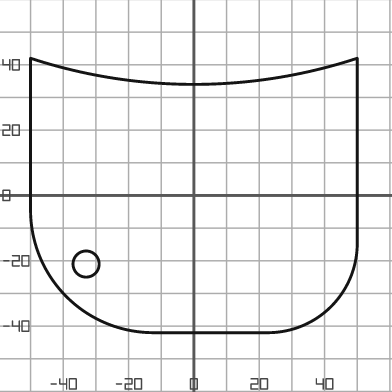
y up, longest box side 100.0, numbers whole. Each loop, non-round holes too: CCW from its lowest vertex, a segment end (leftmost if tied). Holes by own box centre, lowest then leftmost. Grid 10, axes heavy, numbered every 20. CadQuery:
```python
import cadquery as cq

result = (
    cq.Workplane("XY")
    .moveTo(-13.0, -42.0)
    .lineTo(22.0, -42.0)
    .threePointArc((42.0, -34.0), (50.0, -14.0))
    .lineTo(50.0, 42.0)
    .threePointArc((0.0, 34.0), (-50.0, 42.0))
    .lineTo(-50.0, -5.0)
    .threePointArc((-39.0, -31.0), (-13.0, -42.0))
    .close()
    .moveTo(-33.0, -21.0)
    .circle(4.0)
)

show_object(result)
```